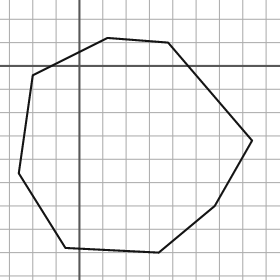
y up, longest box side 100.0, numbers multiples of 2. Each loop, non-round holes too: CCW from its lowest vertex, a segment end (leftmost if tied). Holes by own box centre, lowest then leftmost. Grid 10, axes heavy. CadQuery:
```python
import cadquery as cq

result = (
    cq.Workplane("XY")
    .moveTo(34.0, -80.0)
    .lineTo(58.0, -60.0)
    .lineTo(74.0, -32.0)
    .lineTo(38.0, 10.0)
    .lineTo(12.0, 12.0)
    .lineTo(-20.0, -4.0)
    .lineTo(-26.0, -46.0)
    .lineTo(-6.0, -78.0)
    .close()
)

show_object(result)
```